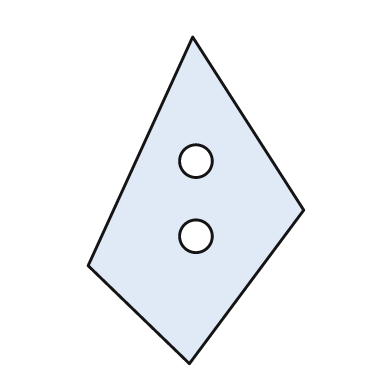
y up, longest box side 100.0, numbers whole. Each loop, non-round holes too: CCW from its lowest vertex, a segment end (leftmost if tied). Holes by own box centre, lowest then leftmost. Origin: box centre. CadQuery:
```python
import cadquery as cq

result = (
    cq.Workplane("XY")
    .moveTo(-2.0, -50.0)
    .lineTo(33.0, -3.0)
    .lineTo(-1.0, 50.0)
    .lineTo(-33.0, -20.0)
    .close()
    .moveTo(0.0, -11.0)
    .circle(5.0)
    .moveTo(0.0, 12.0)
    .circle(5.0)
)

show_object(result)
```